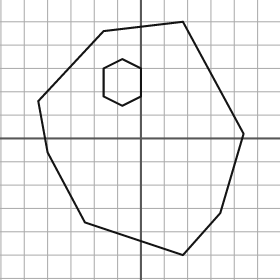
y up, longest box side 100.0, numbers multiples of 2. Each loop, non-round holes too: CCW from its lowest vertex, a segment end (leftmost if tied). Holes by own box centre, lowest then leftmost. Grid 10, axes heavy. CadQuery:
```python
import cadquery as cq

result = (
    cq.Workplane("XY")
    .moveTo(18.0, -50.0)
    .lineTo(34.0, -32.0)
    .lineTo(44.0, 2.0)
    .lineTo(18.0, 50.0)
    .lineTo(-16.0, 46.0)
    .lineTo(-44.0, 16.0)
    .lineTo(-40.0, -6.0)
    .lineTo(-24.0, -36.0)
    .close()
    .moveTo(-8.0, 14.0)
    .lineTo(0.0, 18.0)
    .lineTo(0.0, 30.0)
    .lineTo(-8.0, 34.0)
    .lineTo(-16.0, 30.0)
    .lineTo(-16.0, 18.0)
    .close()
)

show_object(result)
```